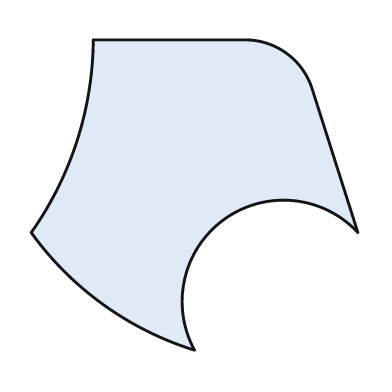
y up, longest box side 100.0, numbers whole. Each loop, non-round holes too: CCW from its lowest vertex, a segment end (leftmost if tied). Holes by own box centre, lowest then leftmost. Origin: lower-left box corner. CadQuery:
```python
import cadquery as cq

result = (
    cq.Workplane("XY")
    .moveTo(50.0, 0.0)
    .threePointArc((59.0, 40.0), (100.0, 36.0))
    .lineTo(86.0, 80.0)
    .threePointArc((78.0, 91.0), (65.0, 95.0))
    .lineTo(19.0, 95.0)
    .threePointArc((14.0, 64.0), (0.0, 36.0))
    .threePointArc((22.0, 14.0), (50.0, 0.0))
    .close()
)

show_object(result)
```